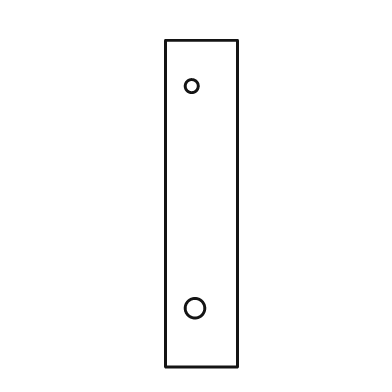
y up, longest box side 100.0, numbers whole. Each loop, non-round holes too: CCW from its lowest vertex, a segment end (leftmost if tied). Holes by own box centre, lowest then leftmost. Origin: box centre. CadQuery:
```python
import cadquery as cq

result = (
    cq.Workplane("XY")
    .moveTo(-11.0, -50.0)
    .lineTo(11.0, -50.0)
    .lineTo(11.0, 50.0)
    .lineTo(-11.0, 50.0)
    .close()
    .moveTo(-2.0, -32.0)
    .circle(3.0)
    .moveTo(-3.0, 36.0)
    .circle(2.0)
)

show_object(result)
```